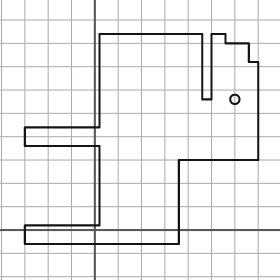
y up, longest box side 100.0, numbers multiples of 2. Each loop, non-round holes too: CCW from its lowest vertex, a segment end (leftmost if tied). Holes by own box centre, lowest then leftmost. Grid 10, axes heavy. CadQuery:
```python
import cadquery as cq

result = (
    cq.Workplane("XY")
    .moveTo(-30.0, -6.0)
    .lineTo(36.0, -6.0)
    .lineTo(36.0, 30.0)
    .lineTo(70.0, 30.0)
    .lineTo(70.0, 72.0)
    .lineTo(66.0, 72.0)
    .lineTo(66.0, 80.0)
    .lineTo(56.0, 80.0)
    .lineTo(56.0, 84.0)
    .lineTo(50.0, 84.0)
    .lineTo(50.0, 56.0)
    .lineTo(46.0, 56.0)
    .lineTo(46.0, 84.0)
    .lineTo(2.0, 84.0)
    .lineTo(2.0, 44.0)
    .lineTo(-30.0, 44.0)
    .lineTo(-30.0, 36.0)
    .lineTo(2.0, 36.0)
    .lineTo(2.0, 2.0)
    .lineTo(-30.0, 2.0)
    .close()
    .moveTo(60.0, 56.0)
    .circle(2.0)
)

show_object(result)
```